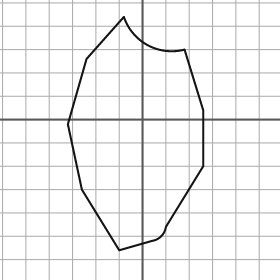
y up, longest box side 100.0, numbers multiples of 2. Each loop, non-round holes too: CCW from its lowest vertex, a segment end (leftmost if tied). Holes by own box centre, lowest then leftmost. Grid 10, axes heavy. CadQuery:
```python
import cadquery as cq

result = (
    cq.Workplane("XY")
    .moveTo(-10.0, -56.0)
    .lineTo(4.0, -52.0)
    .threePointArc((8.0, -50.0), (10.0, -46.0))
    .lineTo(26.0, -20.0)
    .lineTo(26.0, 4.0)
    .lineTo(18.0, 30.0)
    .threePointArc((2.0, 32.0), (-8.0, 44.0))
    .lineTo(-24.0, 26.0)
    .lineTo(-32.0, -2.0)
    .lineTo(-26.0, -30.0)
    .close()
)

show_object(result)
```